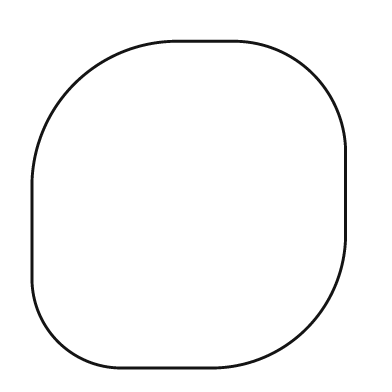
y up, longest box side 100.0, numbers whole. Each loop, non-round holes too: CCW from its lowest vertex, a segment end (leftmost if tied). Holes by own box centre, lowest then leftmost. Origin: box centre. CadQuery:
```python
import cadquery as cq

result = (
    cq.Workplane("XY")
    .moveTo(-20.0, -50.0)
    .lineTo(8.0, -50.0)
    .threePointArc((36.0, -38.0), (48.0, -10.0))
    .lineTo(48.0, 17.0)
    .threePointArc((38.0, 40.0), (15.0, 50.0))
    .lineTo(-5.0, 50.0)
    .threePointArc((-35.0, 37.0), (-48.0, 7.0))
    .lineTo(-48.0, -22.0)
    .threePointArc((-40.0, -42.0), (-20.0, -50.0))
    .close()
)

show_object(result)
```